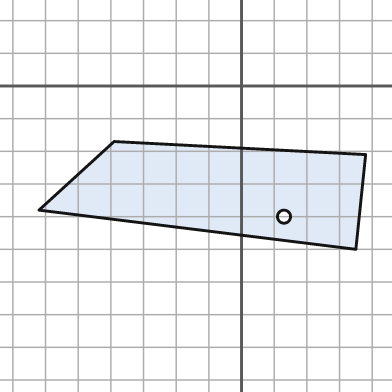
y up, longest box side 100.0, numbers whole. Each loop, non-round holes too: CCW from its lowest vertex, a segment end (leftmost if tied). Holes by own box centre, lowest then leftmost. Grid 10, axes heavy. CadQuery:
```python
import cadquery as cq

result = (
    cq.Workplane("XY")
    .moveTo(35.0, -50.0)
    .lineTo(38.0, -21.0)
    .lineTo(-39.0, -17.0)
    .lineTo(-62.0, -38.0)
    .close()
    .moveTo(13.0, -40.0)
    .circle(2.0)
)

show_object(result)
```